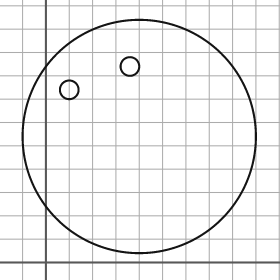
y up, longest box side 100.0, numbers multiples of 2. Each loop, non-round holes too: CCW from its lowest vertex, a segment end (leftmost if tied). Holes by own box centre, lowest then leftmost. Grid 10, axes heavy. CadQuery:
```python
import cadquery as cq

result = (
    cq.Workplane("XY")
    .moveTo(40.0, 54.0)
    .circle(50.0)
    .moveTo(10.0, 74.0)
    .circle(4.0)
    .moveTo(36.0, 84.0)
    .circle(4.0)
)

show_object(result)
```